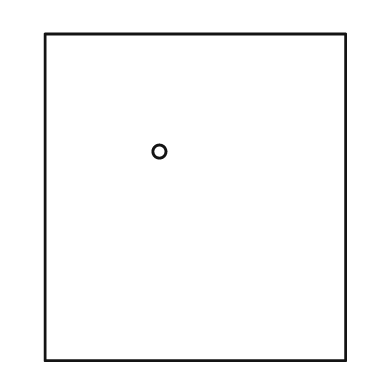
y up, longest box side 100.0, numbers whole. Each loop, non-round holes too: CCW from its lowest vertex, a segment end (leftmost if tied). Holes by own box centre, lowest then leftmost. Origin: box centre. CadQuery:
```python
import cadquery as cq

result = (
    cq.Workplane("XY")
    .moveTo(-46.0, -50.0)
    .lineTo(46.0, -50.0)
    .lineTo(46.0, 50.0)
    .lineTo(-46.0, 50.0)
    .close()
    .moveTo(-11.0, 14.0)
    .circle(2.0)
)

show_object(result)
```